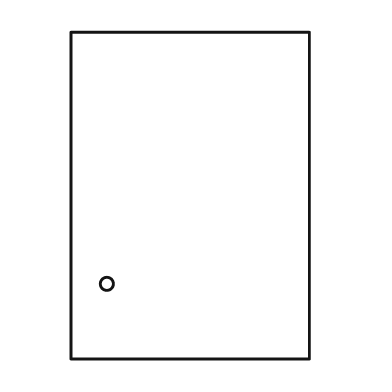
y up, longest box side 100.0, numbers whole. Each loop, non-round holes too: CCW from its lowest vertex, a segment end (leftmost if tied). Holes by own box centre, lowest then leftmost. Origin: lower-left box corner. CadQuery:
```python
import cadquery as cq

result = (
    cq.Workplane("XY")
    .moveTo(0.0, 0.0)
    .lineTo(73.0, 0.0)
    .lineTo(73.0, 100.0)
    .lineTo(0.0, 100.0)
    .close()
    .moveTo(11.0, 23.0)
    .circle(2.0)
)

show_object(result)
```